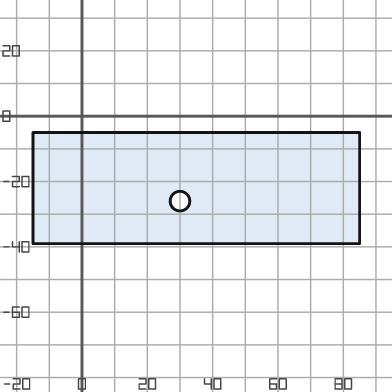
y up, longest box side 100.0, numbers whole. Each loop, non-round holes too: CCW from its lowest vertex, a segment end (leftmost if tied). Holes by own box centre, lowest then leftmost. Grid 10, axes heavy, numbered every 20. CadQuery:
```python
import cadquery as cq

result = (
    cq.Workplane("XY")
    .moveTo(-15.0, -39.0)
    .lineTo(85.0, -39.0)
    .lineTo(85.0, -5.0)
    .lineTo(-15.0, -5.0)
    .close()
    .moveTo(30.0, -26.0)
    .circle(3.0)
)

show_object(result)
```